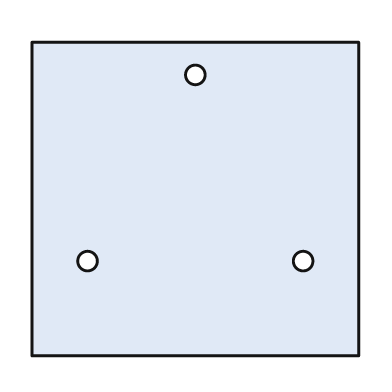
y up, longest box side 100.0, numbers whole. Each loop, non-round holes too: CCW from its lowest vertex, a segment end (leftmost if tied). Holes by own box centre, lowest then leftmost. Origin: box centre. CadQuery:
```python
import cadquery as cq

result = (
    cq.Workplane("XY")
    .moveTo(-50.0, -48.0)
    .lineTo(50.0, -48.0)
    .lineTo(50.0, 48.0)
    .lineTo(-50.0, 48.0)
    .close()
    .moveTo(-33.0, -19.0)
    .circle(3.0)
    .moveTo(33.0, -19.0)
    .circle(3.0)
    .moveTo(0.0, 38.0)
    .circle(3.0)
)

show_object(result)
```